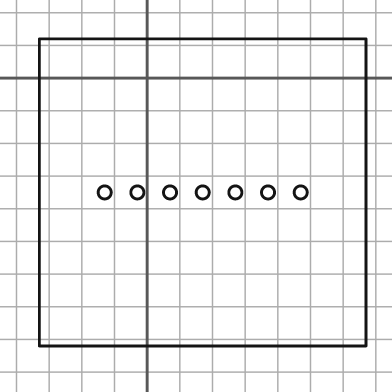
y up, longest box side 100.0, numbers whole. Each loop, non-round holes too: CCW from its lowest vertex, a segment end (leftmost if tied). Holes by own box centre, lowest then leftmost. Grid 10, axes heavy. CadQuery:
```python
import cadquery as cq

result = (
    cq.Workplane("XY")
    .moveTo(-33.0, -82.0)
    .lineTo(67.0, -82.0)
    .lineTo(67.0, 12.0)
    .lineTo(-33.0, 12.0)
    .close()
    .moveTo(-13.0, -35.0)
    .circle(2.0)
    .moveTo(-3.0, -35.0)
    .circle(2.0)
    .moveTo(7.0, -35.0)
    .circle(2.0)
    .moveTo(17.0, -35.0)
    .circle(2.0)
    .moveTo(27.0, -35.0)
    .circle(2.0)
    .moveTo(37.0, -35.0)
    .circle(2.0)
    .moveTo(47.0, -35.0)
    .circle(2.0)
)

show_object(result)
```